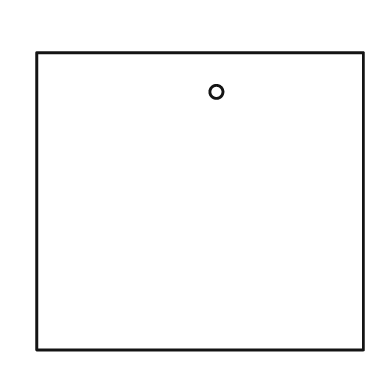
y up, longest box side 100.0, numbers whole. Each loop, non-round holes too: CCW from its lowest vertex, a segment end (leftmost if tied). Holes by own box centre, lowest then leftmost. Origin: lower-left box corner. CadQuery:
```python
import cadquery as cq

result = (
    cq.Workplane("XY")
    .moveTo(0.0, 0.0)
    .lineTo(100.0, 0.0)
    .lineTo(100.0, 91.0)
    .lineTo(0.0, 91.0)
    .close()
    .moveTo(55.0, 79.0)
    .circle(2.0)
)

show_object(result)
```